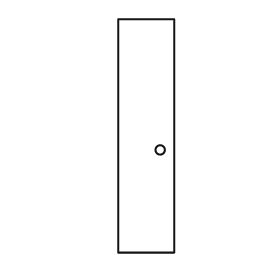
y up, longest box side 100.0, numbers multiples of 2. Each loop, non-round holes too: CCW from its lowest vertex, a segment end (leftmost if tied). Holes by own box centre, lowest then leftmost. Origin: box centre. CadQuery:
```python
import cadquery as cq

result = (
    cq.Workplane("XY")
    .moveTo(-12.0, -50.0)
    .lineTo(12.0, -50.0)
    .lineTo(12.0, 50.0)
    .lineTo(-12.0, 50.0)
    .close()
    .moveTo(6.0, -6.0)
    .circle(2.0)
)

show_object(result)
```